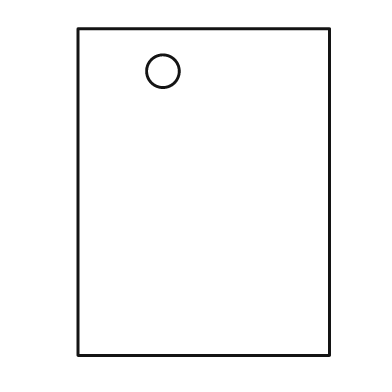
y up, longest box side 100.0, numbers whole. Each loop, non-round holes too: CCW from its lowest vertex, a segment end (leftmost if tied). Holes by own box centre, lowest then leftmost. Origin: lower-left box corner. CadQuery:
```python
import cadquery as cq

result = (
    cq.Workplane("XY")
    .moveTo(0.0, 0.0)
    .lineTo(77.0, 0.0)
    .lineTo(77.0, 100.0)
    .lineTo(0.0, 100.0)
    .close()
    .moveTo(26.0, 87.0)
    .circle(5.0)
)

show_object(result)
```